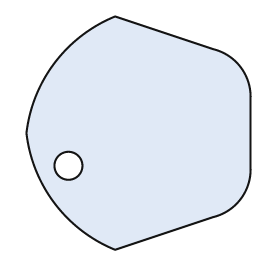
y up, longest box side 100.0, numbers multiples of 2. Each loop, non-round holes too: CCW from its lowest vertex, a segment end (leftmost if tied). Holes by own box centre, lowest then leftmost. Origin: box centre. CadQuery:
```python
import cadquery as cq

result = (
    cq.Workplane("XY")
    .moveTo(-10.0, -50.0)
    .lineTo(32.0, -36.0)
    .threePointArc((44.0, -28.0), (48.0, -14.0))
    .lineTo(48.0, 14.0)
    .threePointArc((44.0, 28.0), (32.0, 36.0))
    .lineTo(-10.0, 50.0)
    .threePointArc((-36.0, 30.0), (-48.0, 0.0))
    .threePointArc((-36.0, -30.0), (-10.0, -50.0))
    .close()
    .moveTo(-30.0, -14.0)
    .circle(6.0)
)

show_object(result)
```